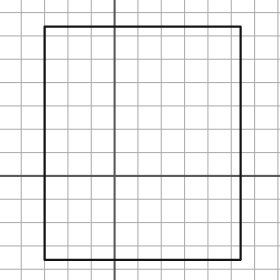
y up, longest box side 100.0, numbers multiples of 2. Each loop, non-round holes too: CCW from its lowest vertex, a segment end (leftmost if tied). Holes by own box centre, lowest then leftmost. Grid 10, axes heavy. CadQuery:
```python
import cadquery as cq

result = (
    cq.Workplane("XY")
    .moveTo(-30.0, -36.0)
    .lineTo(54.0, -36.0)
    .lineTo(54.0, 64.0)
    .lineTo(-30.0, 64.0)
    .close()
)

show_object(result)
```